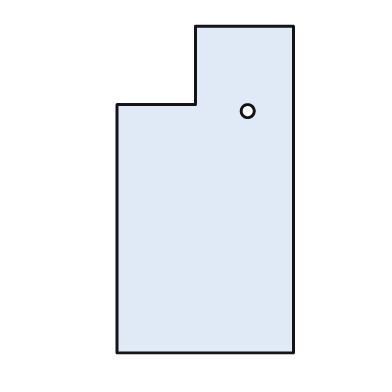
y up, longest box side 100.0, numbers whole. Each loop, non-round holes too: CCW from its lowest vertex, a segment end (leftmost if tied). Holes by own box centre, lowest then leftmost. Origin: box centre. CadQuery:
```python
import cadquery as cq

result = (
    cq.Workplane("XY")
    .moveTo(-27.0, -50.0)
    .lineTo(27.0, -50.0)
    .lineTo(27.0, 50.0)
    .lineTo(-3.0, 50.0)
    .lineTo(-3.0, 26.0)
    .lineTo(-27.0, 26.0)
    .close()
    .moveTo(13.0, 24.0)
    .circle(2.0)
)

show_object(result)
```